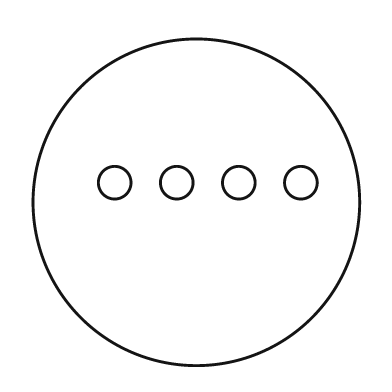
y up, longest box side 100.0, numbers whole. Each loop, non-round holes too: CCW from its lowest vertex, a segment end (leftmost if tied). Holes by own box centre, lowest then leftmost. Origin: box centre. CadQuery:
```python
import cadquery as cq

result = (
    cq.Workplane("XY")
    .moveTo(0.0, 0.0)
    .circle(50.0)
    .moveTo(-25.0, 6.0)
    .circle(5.0)
    .moveTo(-6.0, 6.0)
    .circle(5.0)
    .moveTo(13.0, 6.0)
    .circle(5.0)
    .moveTo(32.0, 6.0)
    .circle(5.0)
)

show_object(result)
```